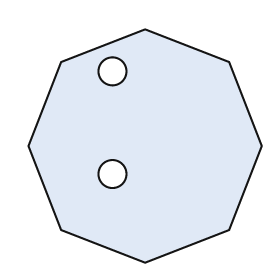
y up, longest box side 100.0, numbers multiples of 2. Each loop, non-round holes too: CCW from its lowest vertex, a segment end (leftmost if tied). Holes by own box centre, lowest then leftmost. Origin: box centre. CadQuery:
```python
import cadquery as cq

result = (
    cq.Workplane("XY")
    .moveTo(0.0, -50.0)
    .lineTo(36.0, -36.0)
    .lineTo(50.0, 0.0)
    .lineTo(36.0, 36.0)
    .lineTo(0.0, 50.0)
    .lineTo(-36.0, 36.0)
    .lineTo(-50.0, 0.0)
    .lineTo(-36.0, -36.0)
    .close()
    .moveTo(-14.0, -12.0)
    .circle(6.0)
    .moveTo(-14.0, 32.0)
    .circle(6.0)
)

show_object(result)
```